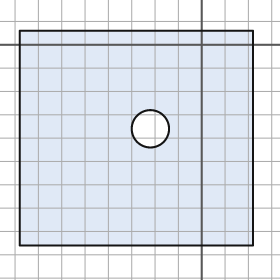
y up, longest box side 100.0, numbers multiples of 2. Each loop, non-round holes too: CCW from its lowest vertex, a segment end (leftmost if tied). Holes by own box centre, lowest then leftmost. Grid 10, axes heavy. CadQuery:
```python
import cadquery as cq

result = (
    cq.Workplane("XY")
    .moveTo(-78.0, -86.0)
    .lineTo(22.0, -86.0)
    .lineTo(22.0, 6.0)
    .lineTo(-78.0, 6.0)
    .close()
    .moveTo(-22.0, -36.0)
    .circle(8.0)
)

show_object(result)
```